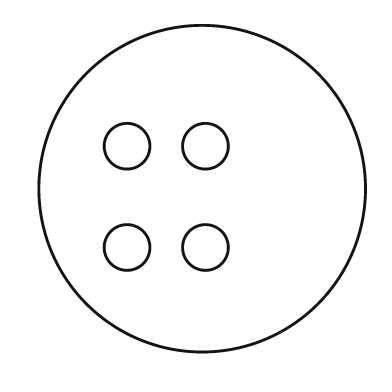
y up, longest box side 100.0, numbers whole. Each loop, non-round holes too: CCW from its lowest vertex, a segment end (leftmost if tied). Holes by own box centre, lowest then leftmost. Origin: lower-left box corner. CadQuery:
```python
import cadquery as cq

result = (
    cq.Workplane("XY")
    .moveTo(50.0, 50.0)
    .circle(50.0)
    .moveTo(27.0, 32.0)
    .circle(7.0)
    .moveTo(51.0, 32.0)
    .circle(7.0)
    .moveTo(27.0, 63.0)
    .circle(7.0)
    .moveTo(51.0, 63.0)
    .circle(7.0)
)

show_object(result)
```